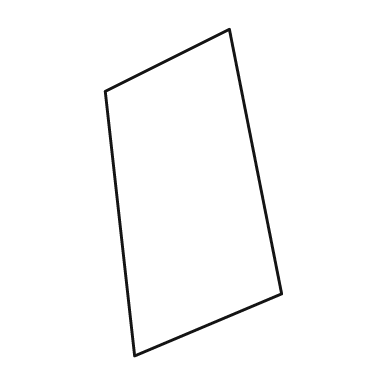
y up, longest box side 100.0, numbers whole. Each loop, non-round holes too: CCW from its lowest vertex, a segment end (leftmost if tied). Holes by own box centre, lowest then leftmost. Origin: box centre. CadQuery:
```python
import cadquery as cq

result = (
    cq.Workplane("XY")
    .moveTo(-18.0, -50.0)
    .lineTo(27.0, -31.0)
    .lineTo(11.0, 50.0)
    .lineTo(-27.0, 31.0)
    .close()
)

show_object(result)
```